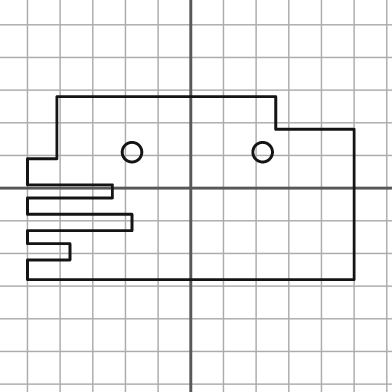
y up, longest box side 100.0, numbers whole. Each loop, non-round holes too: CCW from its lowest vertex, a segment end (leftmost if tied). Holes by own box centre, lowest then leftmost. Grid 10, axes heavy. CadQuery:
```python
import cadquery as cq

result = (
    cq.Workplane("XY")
    .moveTo(-50.0, -28.0)
    .lineTo(50.0, -28.0)
    .lineTo(50.0, 18.0)
    .lineTo(26.0, 18.0)
    .lineTo(26.0, 28.0)
    .lineTo(-41.0, 28.0)
    .lineTo(-41.0, 9.0)
    .lineTo(-50.0, 9.0)
    .lineTo(-50.0, 1.0)
    .lineTo(-24.0, 1.0)
    .lineTo(-24.0, -3.0)
    .lineTo(-50.0, -3.0)
    .lineTo(-50.0, -8.0)
    .lineTo(-18.0, -8.0)
    .lineTo(-18.0, -13.0)
    .lineTo(-50.0, -13.0)
    .lineTo(-50.0, -17.0)
    .lineTo(-37.0, -17.0)
    .lineTo(-37.0, -22.0)
    .lineTo(-50.0, -22.0)
    .close()
    .moveTo(-18.0, 11.0)
    .circle(3.0)
    .moveTo(22.0, 11.0)
    .circle(3.0)
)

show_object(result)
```